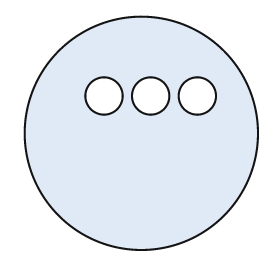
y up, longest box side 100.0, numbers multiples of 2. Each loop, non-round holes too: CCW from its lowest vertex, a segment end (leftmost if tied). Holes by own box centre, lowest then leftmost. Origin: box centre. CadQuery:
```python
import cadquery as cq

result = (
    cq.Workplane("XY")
    .moveTo(0.0, 0.0)
    .circle(50.0)
    .moveTo(-16.0, 16.0)
    .circle(8.0)
    .moveTo(4.0, 16.0)
    .circle(8.0)
    .moveTo(24.0, 16.0)
    .circle(8.0)
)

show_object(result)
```